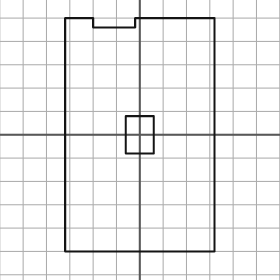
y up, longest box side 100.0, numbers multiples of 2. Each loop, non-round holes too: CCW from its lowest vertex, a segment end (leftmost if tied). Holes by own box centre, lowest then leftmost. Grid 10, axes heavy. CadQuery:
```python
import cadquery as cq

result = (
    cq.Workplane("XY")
    .moveTo(-32.0, -50.0)
    .lineTo(32.0, -50.0)
    .lineTo(32.0, 50.0)
    .lineTo(-2.0, 50.0)
    .lineTo(-2.0, 46.0)
    .lineTo(-20.0, 46.0)
    .lineTo(-20.0, 50.0)
    .lineTo(-32.0, 50.0)
    .close()
    .moveTo(-6.0, -8.0)
    .lineTo(6.0, -8.0)
    .lineTo(6.0, 8.0)
    .lineTo(-6.0, 8.0)
    .close()
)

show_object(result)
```